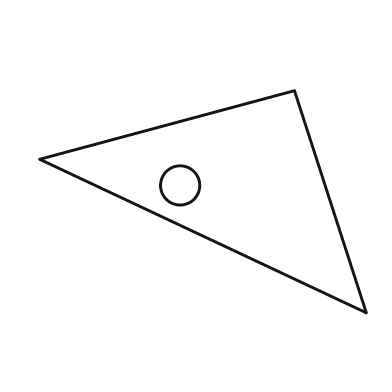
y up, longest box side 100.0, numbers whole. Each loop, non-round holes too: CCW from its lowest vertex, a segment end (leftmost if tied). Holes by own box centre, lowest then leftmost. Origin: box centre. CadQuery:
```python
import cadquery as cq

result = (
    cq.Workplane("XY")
    .moveTo(50.0, -34.0)
    .lineTo(28.0, 34.0)
    .lineTo(-50.0, 13.0)
    .close()
    .moveTo(-7.0, 5.0)
    .circle(6.0)
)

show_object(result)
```